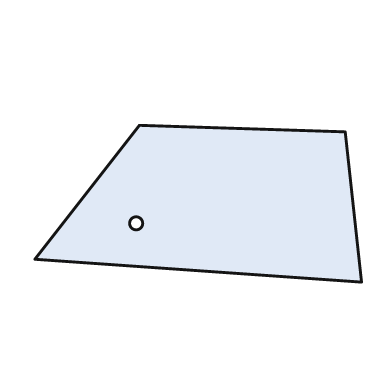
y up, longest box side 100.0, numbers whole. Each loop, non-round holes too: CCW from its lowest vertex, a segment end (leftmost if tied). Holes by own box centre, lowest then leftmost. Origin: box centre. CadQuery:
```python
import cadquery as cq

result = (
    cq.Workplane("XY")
    .moveTo(50.0, -24.0)
    .lineTo(45.0, 22.0)
    .lineTo(-18.0, 24.0)
    .lineTo(-50.0, -17.0)
    .close()
    .moveTo(-19.0, -6.0)
    .circle(2.0)
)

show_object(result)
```